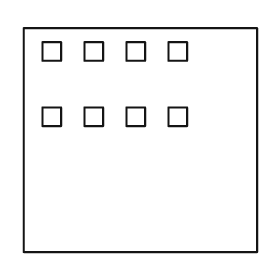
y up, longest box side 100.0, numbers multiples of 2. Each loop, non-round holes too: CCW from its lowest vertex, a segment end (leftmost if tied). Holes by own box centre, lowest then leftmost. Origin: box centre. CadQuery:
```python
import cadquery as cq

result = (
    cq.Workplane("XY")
    .moveTo(-50.0, -48.0)
    .lineTo(50.0, -48.0)
    .lineTo(50.0, 48.0)
    .lineTo(-50.0, 48.0)
    .close()
    .moveTo(-42.0, 6.0)
    .lineTo(-34.0, 6.0)
    .lineTo(-34.0, 14.0)
    .lineTo(-42.0, 14.0)
    .close()
    .moveTo(-24.0, 6.0)
    .lineTo(-16.0, 6.0)
    .lineTo(-16.0, 14.0)
    .lineTo(-24.0, 14.0)
    .close()
    .moveTo(-6.0, 6.0)
    .lineTo(2.0, 6.0)
    .lineTo(2.0, 14.0)
    .lineTo(-6.0, 14.0)
    .close()
    .moveTo(12.0, 6.0)
    .lineTo(20.0, 6.0)
    .lineTo(20.0, 14.0)
    .lineTo(12.0, 14.0)
    .close()
    .moveTo(-42.0, 34.0)
    .lineTo(-34.0, 34.0)
    .lineTo(-34.0, 42.0)
    .lineTo(-42.0, 42.0)
    .close()
    .moveTo(-24.0, 34.0)
    .lineTo(-16.0, 34.0)
    .lineTo(-16.0, 42.0)
    .lineTo(-24.0, 42.0)
    .close()
    .moveTo(-6.0, 34.0)
    .lineTo(2.0, 34.0)
    .lineTo(2.0, 42.0)
    .lineTo(-6.0, 42.0)
    .close()
    .moveTo(12.0, 34.0)
    .lineTo(20.0, 34.0)
    .lineTo(20.0, 42.0)
    .lineTo(12.0, 42.0)
    .close()
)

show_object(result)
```